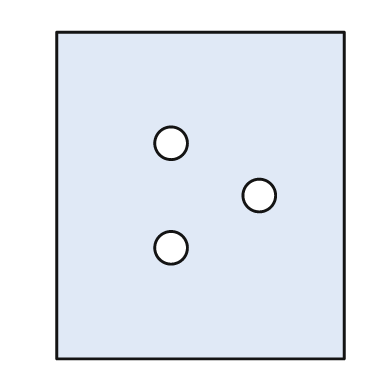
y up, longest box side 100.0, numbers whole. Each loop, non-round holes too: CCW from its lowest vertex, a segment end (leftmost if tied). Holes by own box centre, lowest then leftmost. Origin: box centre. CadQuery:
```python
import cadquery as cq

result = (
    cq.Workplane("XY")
    .moveTo(-44.0, -50.0)
    .lineTo(44.0, -50.0)
    .lineTo(44.0, 50.0)
    .lineTo(-44.0, 50.0)
    .close()
    .moveTo(-9.0, -16.0)
    .circle(5.0)
    .moveTo(18.0, 0.0)
    .circle(5.0)
    .moveTo(-9.0, 16.0)
    .circle(5.0)
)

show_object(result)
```